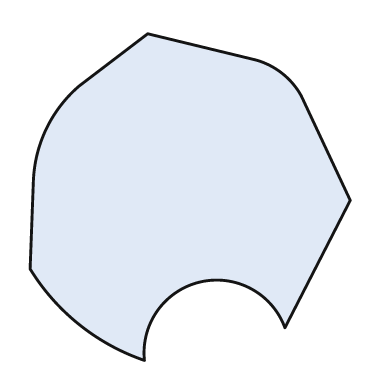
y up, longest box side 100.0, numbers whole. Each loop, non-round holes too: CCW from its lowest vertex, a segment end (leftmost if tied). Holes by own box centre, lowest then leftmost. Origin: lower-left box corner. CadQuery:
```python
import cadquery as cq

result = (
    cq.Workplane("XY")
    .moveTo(35.0, 0.0)
    .threePointArc((52.0, 24.0), (78.0, 10.0))
    .lineTo(98.0, 49.0)
    .lineTo(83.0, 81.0)
    .threePointArc((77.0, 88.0), (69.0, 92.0))
    .lineTo(36.0, 100.0)
    .lineTo(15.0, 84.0)
    .threePointArc((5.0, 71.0), (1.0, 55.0))
    .lineTo(0.0, 28.0)
    .threePointArc((15.0, 11.0), (35.0, 0.0))
    .close()
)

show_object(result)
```